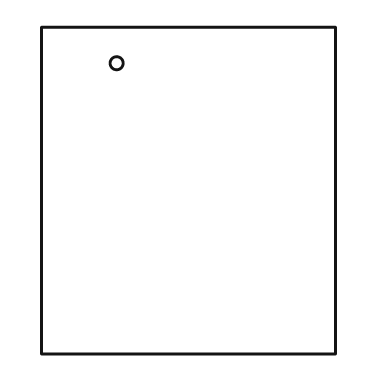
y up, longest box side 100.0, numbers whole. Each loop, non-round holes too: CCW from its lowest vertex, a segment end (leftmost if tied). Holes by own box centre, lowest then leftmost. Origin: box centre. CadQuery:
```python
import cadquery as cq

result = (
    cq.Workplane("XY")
    .moveTo(-45.0, -50.0)
    .lineTo(45.0, -50.0)
    .lineTo(45.0, 50.0)
    .lineTo(-45.0, 50.0)
    .close()
    .moveTo(-22.0, 39.0)
    .circle(2.0)
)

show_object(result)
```